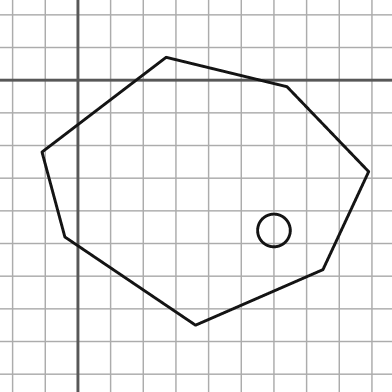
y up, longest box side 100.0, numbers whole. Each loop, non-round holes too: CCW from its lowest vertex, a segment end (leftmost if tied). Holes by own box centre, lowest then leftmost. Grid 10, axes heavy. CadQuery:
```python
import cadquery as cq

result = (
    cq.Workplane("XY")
    .moveTo(36.0, -75.0)
    .lineTo(75.0, -58.0)
    .lineTo(89.0, -28.0)
    .lineTo(64.0, -2.0)
    .lineTo(27.0, 7.0)
    .lineTo(-11.0, -22.0)
    .lineTo(-4.0, -48.0)
    .close()
    .moveTo(60.0, -46.0)
    .circle(5.0)
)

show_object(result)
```